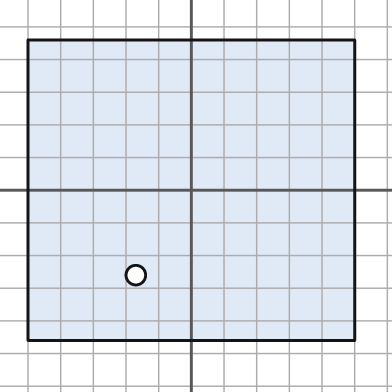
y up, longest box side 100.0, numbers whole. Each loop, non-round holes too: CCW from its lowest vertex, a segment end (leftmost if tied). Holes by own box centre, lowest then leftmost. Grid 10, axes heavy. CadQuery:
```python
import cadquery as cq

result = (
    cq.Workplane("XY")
    .moveTo(-50.0, -46.0)
    .lineTo(50.0, -46.0)
    .lineTo(50.0, 46.0)
    .lineTo(-50.0, 46.0)
    .close()
    .moveTo(-17.0, -26.0)
    .circle(3.0)
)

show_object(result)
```